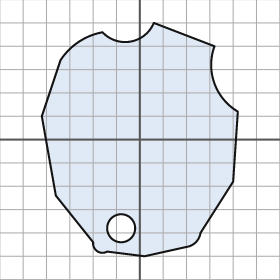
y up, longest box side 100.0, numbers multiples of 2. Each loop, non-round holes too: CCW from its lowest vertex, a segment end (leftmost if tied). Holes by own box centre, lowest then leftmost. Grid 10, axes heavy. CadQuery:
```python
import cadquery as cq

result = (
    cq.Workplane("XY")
    .moveTo(2.0, -50.0)
    .lineTo(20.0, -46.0)
    .threePointArc((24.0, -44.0), (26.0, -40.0))
    .lineTo(40.0, -18.0)
    .lineTo(42.0, 12.0)
    .threePointArc((32.0, 24.0), (32.0, 40.0))
    .lineTo(6.0, 50.0)
    .threePointArc((-4.0, 42.0), (-16.0, 46.0))
    .threePointArc((-26.0, 42.0), (-34.0, 34.0))
    .lineTo(-42.0, 10.0)
    .lineTo(-36.0, -24.0)
    .lineTo(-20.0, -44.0)
    .threePointArc((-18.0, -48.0), (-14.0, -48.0))
    .close()
    .moveTo(-8.0, -38.0)
    .circle(6.0)
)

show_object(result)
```